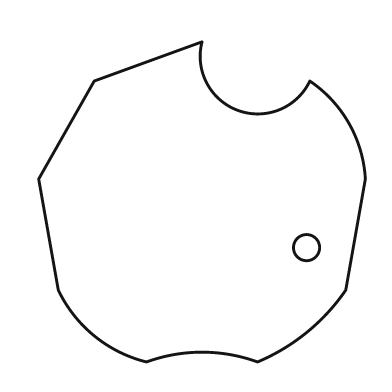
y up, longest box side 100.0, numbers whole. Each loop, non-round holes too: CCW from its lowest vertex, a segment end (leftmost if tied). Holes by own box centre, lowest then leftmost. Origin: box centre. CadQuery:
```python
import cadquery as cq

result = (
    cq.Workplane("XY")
    .moveTo(-17.0, -49.0)
    .threePointArc((0.0, -46.0), (17.0, -49.0))
    .threePointArc((32.0, -40.0), (44.0, -27.0))
    .lineTo(50.0, 7.0)
    .threePointArc((45.0, 24.0), (33.0, 37.0))
    .threePointArc((11.0, 28.0), (0.0, 49.0))
    .lineTo(-33.0, 37.0)
    .lineTo(-50.0, 7.0)
    .lineTo(-44.0, -27.0)
    .threePointArc((-33.0, -41.0), (-17.0, -49.0))
    .close()
    .moveTo(32.0, -14.0)
    .circle(4.0)
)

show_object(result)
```